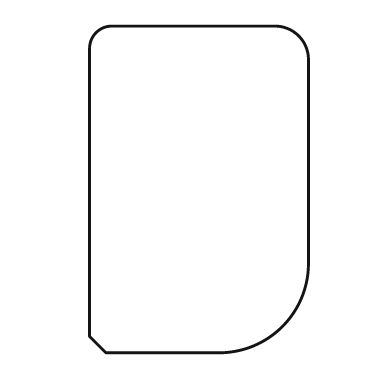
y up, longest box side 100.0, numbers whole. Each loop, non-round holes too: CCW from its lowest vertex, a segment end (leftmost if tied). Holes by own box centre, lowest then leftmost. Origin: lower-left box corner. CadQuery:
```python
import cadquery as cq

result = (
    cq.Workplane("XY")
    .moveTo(5.0, 0.0)
    .lineTo(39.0, 0.0)
    .threePointArc((59.0, 8.0), (67.0, 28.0))
    .lineTo(67.0, 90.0)
    .threePointArc((64.0, 97.0), (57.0, 100.0))
    .lineTo(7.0, 100.0)
    .threePointArc((2.0, 98.0), (0.0, 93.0))
    .lineTo(0.0, 5.0)
    .close()
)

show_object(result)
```